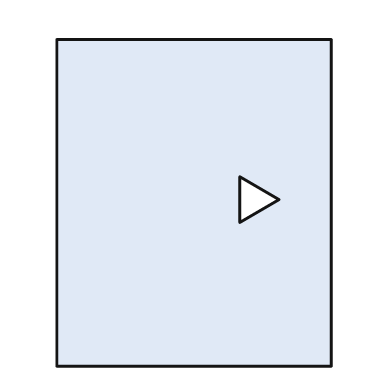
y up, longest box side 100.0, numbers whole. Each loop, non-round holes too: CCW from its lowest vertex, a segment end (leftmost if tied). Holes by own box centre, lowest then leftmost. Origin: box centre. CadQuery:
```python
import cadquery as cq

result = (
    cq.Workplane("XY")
    .moveTo(-42.0, -50.0)
    .lineTo(42.0, -50.0)
    .lineTo(42.0, 50.0)
    .lineTo(-42.0, 50.0)
    .close()
    .moveTo(14.0, -6.0)
    .lineTo(26.0, 1.0)
    .lineTo(14.0, 8.0)
    .close()
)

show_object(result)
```